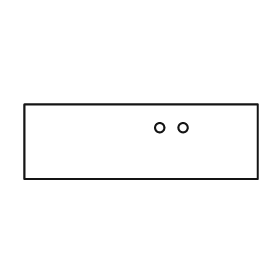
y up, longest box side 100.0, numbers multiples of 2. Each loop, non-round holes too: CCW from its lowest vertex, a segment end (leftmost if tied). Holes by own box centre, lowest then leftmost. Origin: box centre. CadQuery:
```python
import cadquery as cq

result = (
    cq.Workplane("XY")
    .moveTo(-50.0, -16.0)
    .lineTo(50.0, -16.0)
    .lineTo(50.0, 16.0)
    .lineTo(-50.0, 16.0)
    .close()
    .moveTo(8.0, 6.0)
    .circle(2.0)
    .moveTo(18.0, 6.0)
    .circle(2.0)
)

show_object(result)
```